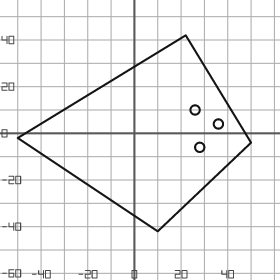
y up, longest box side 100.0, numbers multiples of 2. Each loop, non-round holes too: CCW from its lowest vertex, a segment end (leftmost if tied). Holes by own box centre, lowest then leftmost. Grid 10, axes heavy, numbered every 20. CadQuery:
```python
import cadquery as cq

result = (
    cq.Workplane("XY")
    .moveTo(10.0, -42.0)
    .lineTo(50.0, -4.0)
    .lineTo(22.0, 42.0)
    .lineTo(-50.0, -2.0)
    .close()
    .moveTo(28.0, -6.0)
    .circle(2.0)
    .moveTo(36.0, 4.0)
    .circle(2.0)
    .moveTo(26.0, 10.0)
    .circle(2.0)
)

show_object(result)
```